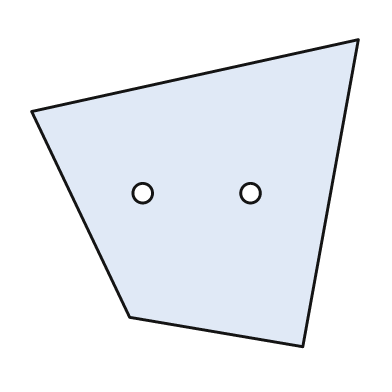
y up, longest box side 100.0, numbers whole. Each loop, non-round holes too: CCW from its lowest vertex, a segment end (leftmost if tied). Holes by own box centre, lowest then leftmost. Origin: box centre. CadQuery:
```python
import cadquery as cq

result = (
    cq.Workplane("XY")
    .moveTo(33.0, -47.0)
    .lineTo(50.0, 47.0)
    .lineTo(-50.0, 25.0)
    .lineTo(-20.0, -38.0)
    .close()
    .moveTo(-16.0, 0.0)
    .circle(3.0)
    .moveTo(17.0, 0.0)
    .circle(3.0)
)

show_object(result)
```